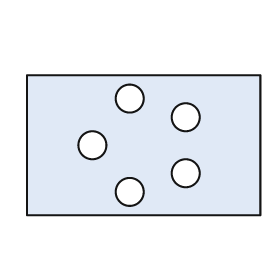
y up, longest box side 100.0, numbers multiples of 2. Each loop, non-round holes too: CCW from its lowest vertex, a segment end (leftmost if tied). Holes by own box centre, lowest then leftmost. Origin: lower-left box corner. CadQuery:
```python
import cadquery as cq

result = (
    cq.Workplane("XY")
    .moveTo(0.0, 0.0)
    .lineTo(100.0, 0.0)
    .lineTo(100.0, 60.0)
    .lineTo(0.0, 60.0)
    .close()
    .moveTo(44.0, 10.0)
    .circle(6.0)
    .moveTo(68.0, 18.0)
    .circle(6.0)
    .moveTo(28.0, 30.0)
    .circle(6.0)
    .moveTo(68.0, 42.0)
    .circle(6.0)
    .moveTo(44.0, 50.0)
    .circle(6.0)
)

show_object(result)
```